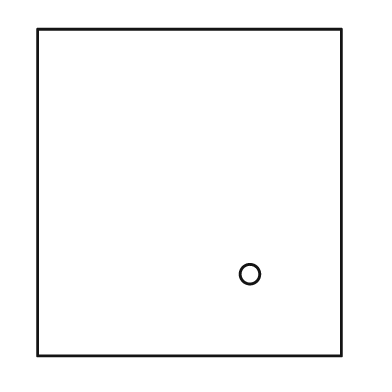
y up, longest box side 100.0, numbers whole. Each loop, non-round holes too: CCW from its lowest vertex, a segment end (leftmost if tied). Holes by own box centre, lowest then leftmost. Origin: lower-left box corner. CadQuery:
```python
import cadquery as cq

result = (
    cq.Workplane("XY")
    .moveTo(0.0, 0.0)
    .lineTo(93.0, 0.0)
    .lineTo(93.0, 100.0)
    .lineTo(0.0, 100.0)
    .close()
    .moveTo(65.0, 25.0)
    .circle(3.0)
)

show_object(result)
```